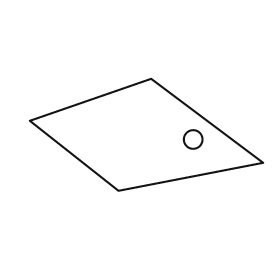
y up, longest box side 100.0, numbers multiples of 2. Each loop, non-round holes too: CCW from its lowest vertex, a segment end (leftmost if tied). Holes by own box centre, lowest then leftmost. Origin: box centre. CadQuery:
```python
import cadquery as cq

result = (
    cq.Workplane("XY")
    .moveTo(-12.0, -24.0)
    .lineTo(50.0, -12.0)
    .lineTo(2.0, 24.0)
    .lineTo(-50.0, 6.0)
    .close()
    .moveTo(20.0, -2.0)
    .circle(4.0)
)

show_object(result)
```